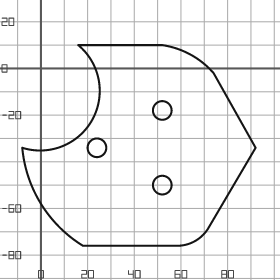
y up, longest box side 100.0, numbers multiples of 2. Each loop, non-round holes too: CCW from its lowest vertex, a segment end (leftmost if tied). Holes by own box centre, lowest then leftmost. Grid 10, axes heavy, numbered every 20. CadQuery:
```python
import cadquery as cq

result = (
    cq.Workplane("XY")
    .moveTo(18.0, -76.0)
    .lineTo(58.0, -76.0)
    .threePointArc((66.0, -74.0), (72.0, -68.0))
    .lineTo(92.0, -34.0)
    .lineTo(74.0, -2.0)
    .threePointArc((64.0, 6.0), (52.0, 10.0))
    .lineTo(16.0, 10.0)
    .threePointArc((22.0, -22.0), (-8.0, -34.0))
    .threePointArc((0.0, -58.0), (18.0, -76.0))
    .close()
    .moveTo(52.0, -50.0)
    .circle(4.0)
    .moveTo(24.0, -34.0)
    .circle(4.0)
    .moveTo(52.0, -18.0)
    .circle(4.0)
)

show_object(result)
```